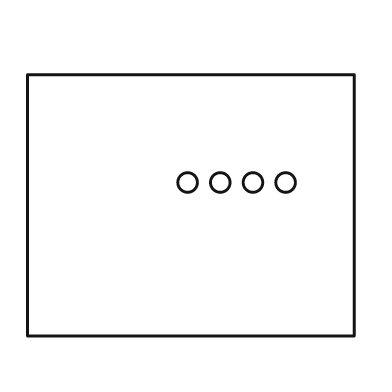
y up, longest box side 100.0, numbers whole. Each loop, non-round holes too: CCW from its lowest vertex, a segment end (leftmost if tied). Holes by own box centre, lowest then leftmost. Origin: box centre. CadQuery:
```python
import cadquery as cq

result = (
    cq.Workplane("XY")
    .moveTo(-50.0, -40.0)
    .lineTo(50.0, -40.0)
    .lineTo(50.0, 40.0)
    .lineTo(-50.0, 40.0)
    .close()
    .moveTo(-1.0, 7.0)
    .circle(3.0)
    .moveTo(9.0, 7.0)
    .circle(3.0)
    .moveTo(19.0, 7.0)
    .circle(3.0)
    .moveTo(29.0, 7.0)
    .circle(3.0)
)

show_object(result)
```